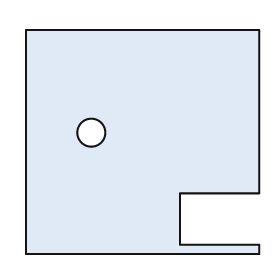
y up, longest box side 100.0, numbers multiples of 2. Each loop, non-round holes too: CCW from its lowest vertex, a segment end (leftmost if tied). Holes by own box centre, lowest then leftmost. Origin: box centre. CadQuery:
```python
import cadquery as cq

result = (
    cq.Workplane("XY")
    .moveTo(-50.0, -48.0)
    .lineTo(50.0, -48.0)
    .lineTo(50.0, -44.0)
    .lineTo(16.0, -44.0)
    .lineTo(16.0, -22.0)
    .lineTo(50.0, -22.0)
    .lineTo(50.0, 48.0)
    .lineTo(-50.0, 48.0)
    .close()
    .moveTo(-22.0, 4.0)
    .circle(6.0)
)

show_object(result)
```